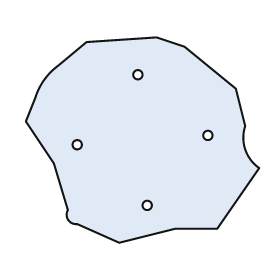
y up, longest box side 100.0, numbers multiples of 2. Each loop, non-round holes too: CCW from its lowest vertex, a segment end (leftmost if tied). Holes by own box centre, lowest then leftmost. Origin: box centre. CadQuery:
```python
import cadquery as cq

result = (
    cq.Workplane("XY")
    .moveTo(-10.0, -44.0)
    .lineTo(14.0, -38.0)
    .lineTo(32.0, -38.0)
    .lineTo(50.0, -12.0)
    .threePointArc((44.0, -4.0), (44.0, 6.0))
    .lineTo(40.0, 22.0)
    .lineTo(18.0, 40.0)
    .lineTo(6.0, 44.0)
    .lineTo(-24.0, 42.0)
    .lineTo(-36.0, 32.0)
    .threePointArc((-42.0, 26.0), (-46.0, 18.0))
    .lineTo(-50.0, 8.0)
    .lineTo(-38.0, -10.0)
    .lineTo(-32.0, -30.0)
    .threePointArc((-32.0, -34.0), (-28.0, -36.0))
    .close()
    .moveTo(2.0, -28.0)
    .circle(2.0)
    .moveTo(-28.0, -2.0)
    .circle(2.0)
    .moveTo(28.0, 2.0)
    .circle(2.0)
    .moveTo(-2.0, 28.0)
    .circle(2.0)
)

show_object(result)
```